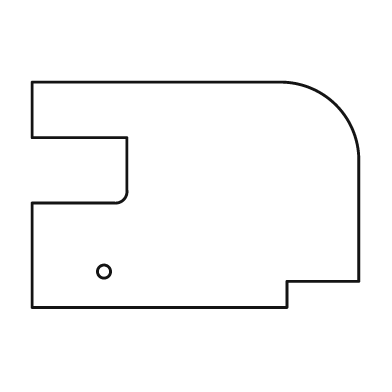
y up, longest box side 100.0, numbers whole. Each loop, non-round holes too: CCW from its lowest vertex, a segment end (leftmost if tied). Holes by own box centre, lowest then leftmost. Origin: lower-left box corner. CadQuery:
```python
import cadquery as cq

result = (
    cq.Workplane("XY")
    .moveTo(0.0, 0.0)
    .lineTo(78.0, 0.0)
    .lineTo(78.0, 8.0)
    .lineTo(100.0, 8.0)
    .lineTo(100.0, 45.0)
    .threePointArc((93.0, 62.0), (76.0, 69.0))
    .lineTo(0.0, 69.0)
    .lineTo(0.0, 52.0)
    .lineTo(29.0, 52.0)
    .lineTo(29.0, 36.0)
    .threePointArc((28.0, 33.0), (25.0, 32.0))
    .lineTo(0.0, 32.0)
    .close()
    .moveTo(22.0, 11.0)
    .circle(2.0)
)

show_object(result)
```